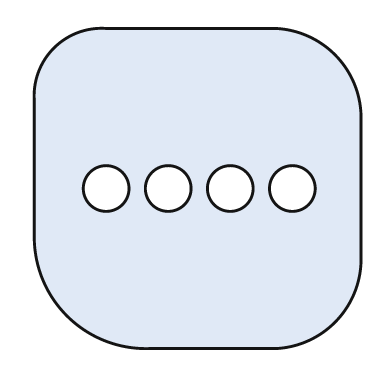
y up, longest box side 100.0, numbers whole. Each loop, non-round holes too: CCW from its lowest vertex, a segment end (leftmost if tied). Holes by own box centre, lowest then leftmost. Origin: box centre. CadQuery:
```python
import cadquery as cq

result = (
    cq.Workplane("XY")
    .moveTo(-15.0, -49.0)
    .lineTo(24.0, -49.0)
    .threePointArc((42.0, -41.0), (50.0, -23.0))
    .lineTo(50.0, 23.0)
    .threePointArc((42.0, 41.0), (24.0, 49.0))
    .lineTo(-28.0, 49.0)
    .threePointArc((-44.0, 43.0), (-50.0, 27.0))
    .lineTo(-50.0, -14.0)
    .threePointArc((-40.0, -39.0), (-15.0, -49.0))
    .close()
    .moveTo(-28.0, 0.0)
    .circle(7.0)
    .moveTo(-9.0, 0.0)
    .circle(7.0)
    .moveTo(10.0, 0.0)
    .circle(7.0)
    .moveTo(29.0, 0.0)
    .circle(7.0)
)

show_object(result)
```